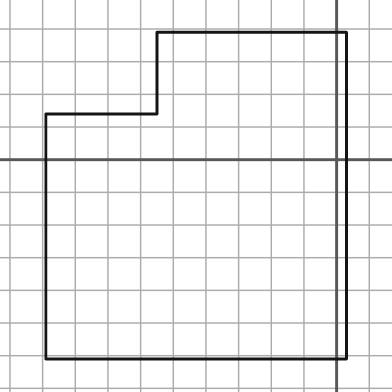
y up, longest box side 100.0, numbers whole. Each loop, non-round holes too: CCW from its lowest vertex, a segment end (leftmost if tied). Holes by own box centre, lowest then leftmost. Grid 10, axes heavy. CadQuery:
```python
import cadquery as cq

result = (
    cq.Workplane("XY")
    .moveTo(-89.0, -61.0)
    .lineTo(3.0, -61.0)
    .lineTo(3.0, 39.0)
    .lineTo(-55.0, 39.0)
    .lineTo(-55.0, 14.0)
    .lineTo(-89.0, 14.0)
    .close()
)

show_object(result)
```